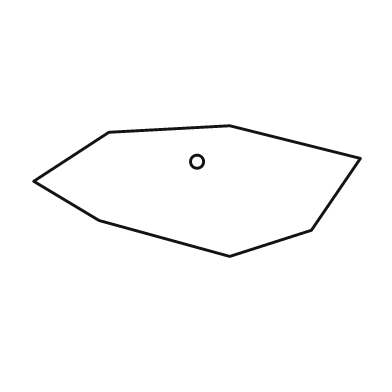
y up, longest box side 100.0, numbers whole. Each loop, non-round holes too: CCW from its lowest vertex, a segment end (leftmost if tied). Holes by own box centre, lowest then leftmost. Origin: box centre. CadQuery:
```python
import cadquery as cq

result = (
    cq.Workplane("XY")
    .moveTo(10.0, -20.0)
    .lineTo(35.0, -12.0)
    .lineTo(50.0, 10.0)
    .lineTo(10.0, 20.0)
    .lineTo(-27.0, 18.0)
    .lineTo(-50.0, 3.0)
    .lineTo(-30.0, -9.0)
    .close()
    .moveTo(0.0, 9.0)
    .circle(2.0)
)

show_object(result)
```